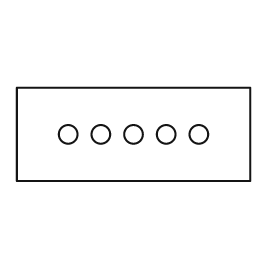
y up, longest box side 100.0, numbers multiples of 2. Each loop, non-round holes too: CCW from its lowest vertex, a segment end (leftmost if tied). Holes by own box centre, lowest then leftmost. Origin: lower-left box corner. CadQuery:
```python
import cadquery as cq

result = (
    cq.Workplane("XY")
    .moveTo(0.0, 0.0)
    .lineTo(100.0, 0.0)
    .lineTo(100.0, 40.0)
    .lineTo(0.0, 40.0)
    .close()
    .moveTo(22.0, 20.0)
    .circle(4.0)
    .moveTo(36.0, 20.0)
    .circle(4.0)
    .moveTo(50.0, 20.0)
    .circle(4.0)
    .moveTo(64.0, 20.0)
    .circle(4.0)
    .moveTo(78.0, 20.0)
    .circle(4.0)
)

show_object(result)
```